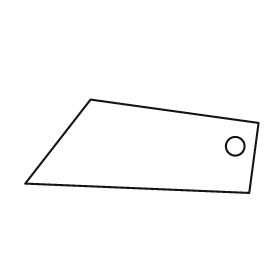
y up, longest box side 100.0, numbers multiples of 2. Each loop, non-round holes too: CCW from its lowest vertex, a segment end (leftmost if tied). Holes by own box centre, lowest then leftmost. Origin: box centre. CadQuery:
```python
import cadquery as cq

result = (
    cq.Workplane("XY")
    .moveTo(46.0, -20.0)
    .lineTo(50.0, 10.0)
    .lineTo(-22.0, 20.0)
    .lineTo(-50.0, -16.0)
    .close()
    .moveTo(40.0, 0.0)
    .circle(4.0)
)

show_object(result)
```